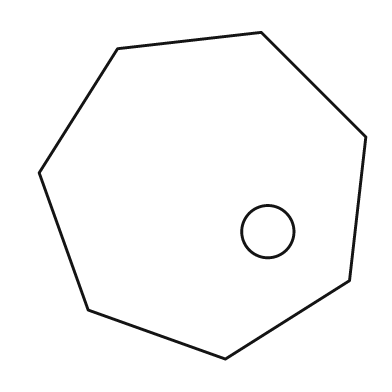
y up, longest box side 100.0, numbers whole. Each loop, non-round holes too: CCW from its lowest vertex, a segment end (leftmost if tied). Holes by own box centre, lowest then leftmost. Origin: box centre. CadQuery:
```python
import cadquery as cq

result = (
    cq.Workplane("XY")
    .moveTo(7.0, -50.0)
    .lineTo(45.0, -26.0)
    .lineTo(50.0, 18.0)
    .lineTo(18.0, 50.0)
    .lineTo(-26.0, 45.0)
    .lineTo(-50.0, 7.0)
    .lineTo(-35.0, -35.0)
    .close()
    .moveTo(20.0, -11.0)
    .circle(8.0)
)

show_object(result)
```